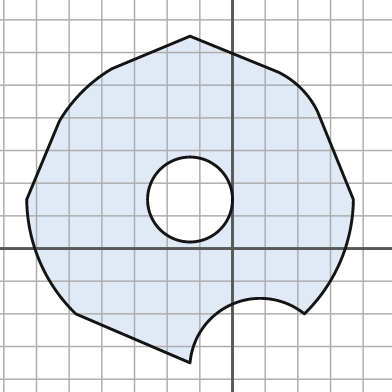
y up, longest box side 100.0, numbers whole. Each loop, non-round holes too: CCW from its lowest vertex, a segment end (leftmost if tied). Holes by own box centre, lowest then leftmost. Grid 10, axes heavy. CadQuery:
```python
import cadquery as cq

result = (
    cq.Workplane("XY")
    .moveTo(-13.0, -35.0)
    .threePointArc((0.0, -17.0), (22.0, -20.0))
    .threePointArc((33.0, -4.0), (37.0, 15.0))
    .lineTo(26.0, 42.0)
    .threePointArc((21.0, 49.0), (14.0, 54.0))
    .lineTo(-13.0, 65.0)
    .lineTo(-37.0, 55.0)
    .threePointArc((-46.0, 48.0), (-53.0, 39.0))
    .lineTo(-63.0, 15.0)
    .threePointArc((-59.0, -4.0), (-48.0, -20.0))
    .close()
    .moveTo(-13.0, 15.0)
    .circle(13.0)
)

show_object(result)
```